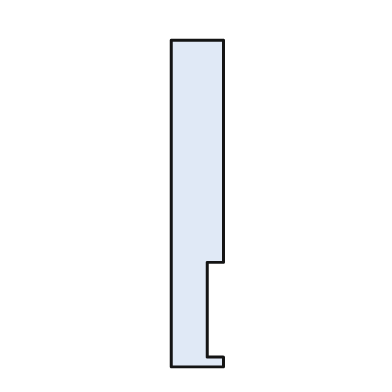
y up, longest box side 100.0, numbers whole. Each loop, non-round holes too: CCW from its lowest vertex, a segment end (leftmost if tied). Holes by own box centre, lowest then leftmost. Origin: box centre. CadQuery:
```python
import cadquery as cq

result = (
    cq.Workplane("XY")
    .moveTo(-8.0, -50.0)
    .lineTo(8.0, -50.0)
    .lineTo(8.0, -47.0)
    .lineTo(3.0, -47.0)
    .lineTo(3.0, -18.0)
    .lineTo(8.0, -18.0)
    .lineTo(8.0, 50.0)
    .lineTo(-8.0, 50.0)
    .close()
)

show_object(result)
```